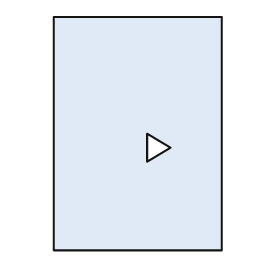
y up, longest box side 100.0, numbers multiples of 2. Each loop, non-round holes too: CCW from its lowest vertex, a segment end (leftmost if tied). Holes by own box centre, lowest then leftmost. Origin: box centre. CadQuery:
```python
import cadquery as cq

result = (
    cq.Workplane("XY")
    .moveTo(-36.0, -50.0)
    .lineTo(36.0, -50.0)
    .lineTo(36.0, 50.0)
    .lineTo(-36.0, 50.0)
    .close()
    .moveTo(4.0, -12.0)
    .lineTo(14.0, -6.0)
    .lineTo(4.0, 0.0)
    .close()
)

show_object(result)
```